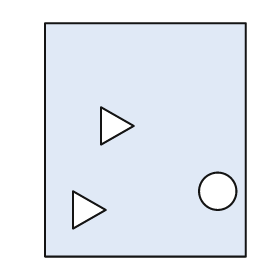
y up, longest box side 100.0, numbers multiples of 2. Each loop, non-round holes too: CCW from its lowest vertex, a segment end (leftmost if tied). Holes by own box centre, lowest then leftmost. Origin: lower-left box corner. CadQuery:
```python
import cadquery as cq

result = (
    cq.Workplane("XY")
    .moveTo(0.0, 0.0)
    .lineTo(86.0, 0.0)
    .lineTo(86.0, 100.0)
    .lineTo(0.0, 100.0)
    .close()
    .moveTo(12.0, 12.0)
    .lineTo(26.0, 20.0)
    .lineTo(12.0, 28.0)
    .close()
    .moveTo(74.0, 28.0)
    .circle(8.0)
    .moveTo(24.0, 48.0)
    .lineTo(38.0, 56.0)
    .lineTo(24.0, 64.0)
    .close()
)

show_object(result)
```